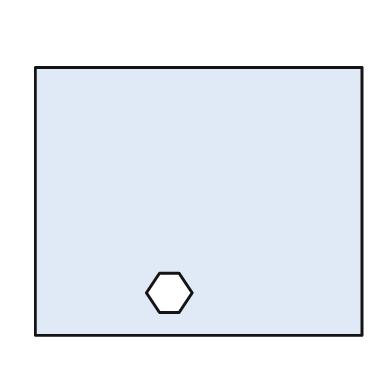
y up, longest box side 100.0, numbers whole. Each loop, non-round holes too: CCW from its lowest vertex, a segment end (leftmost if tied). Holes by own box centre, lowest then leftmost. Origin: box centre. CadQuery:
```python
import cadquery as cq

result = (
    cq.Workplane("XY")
    .moveTo(-50.0, -41.0)
    .lineTo(50.0, -41.0)
    .lineTo(50.0, 41.0)
    .lineTo(-50.0, 41.0)
    .close()
    .moveTo(-12.0, -34.0)
    .lineTo(-6.0, -34.0)
    .lineTo(-2.0, -28.0)
    .lineTo(-6.0, -22.0)
    .lineTo(-12.0, -22.0)
    .lineTo(-16.0, -28.0)
    .close()
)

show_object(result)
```